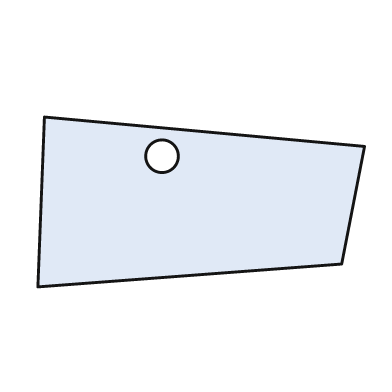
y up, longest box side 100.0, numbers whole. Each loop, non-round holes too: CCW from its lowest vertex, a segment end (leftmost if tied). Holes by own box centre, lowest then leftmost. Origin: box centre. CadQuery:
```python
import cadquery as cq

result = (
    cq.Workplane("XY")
    .moveTo(-50.0, -26.0)
    .lineTo(43.0, -19.0)
    .lineTo(50.0, 17.0)
    .lineTo(-48.0, 26.0)
    .close()
    .moveTo(-12.0, 14.0)
    .circle(5.0)
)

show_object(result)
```